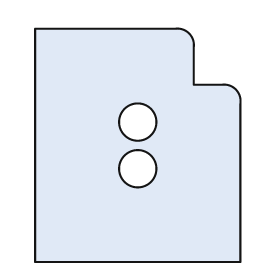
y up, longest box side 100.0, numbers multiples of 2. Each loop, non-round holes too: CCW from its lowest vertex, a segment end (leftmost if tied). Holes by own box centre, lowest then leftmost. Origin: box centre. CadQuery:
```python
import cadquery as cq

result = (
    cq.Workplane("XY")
    .moveTo(-44.0, -50.0)
    .lineTo(44.0, -50.0)
    .lineTo(44.0, 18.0)
    .threePointArc((42.0, 24.0), (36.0, 26.0))
    .lineTo(24.0, 26.0)
    .lineTo(24.0, 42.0)
    .threePointArc((22.0, 48.0), (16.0, 50.0))
    .lineTo(-44.0, 50.0)
    .close()
    .moveTo(0.0, -10.0)
    .circle(8.0)
    .moveTo(0.0, 10.0)
    .circle(8.0)
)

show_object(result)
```